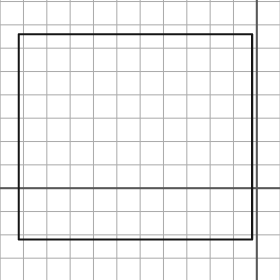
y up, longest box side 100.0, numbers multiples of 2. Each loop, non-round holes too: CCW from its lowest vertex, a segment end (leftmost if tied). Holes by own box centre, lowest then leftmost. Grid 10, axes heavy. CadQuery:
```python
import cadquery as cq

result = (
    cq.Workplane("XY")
    .moveTo(-102.0, -22.0)
    .lineTo(-2.0, -22.0)
    .lineTo(-2.0, 66.0)
    .lineTo(-102.0, 66.0)
    .close()
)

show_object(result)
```